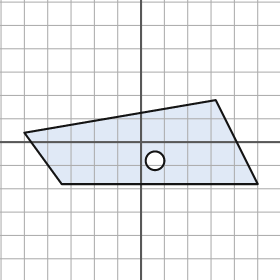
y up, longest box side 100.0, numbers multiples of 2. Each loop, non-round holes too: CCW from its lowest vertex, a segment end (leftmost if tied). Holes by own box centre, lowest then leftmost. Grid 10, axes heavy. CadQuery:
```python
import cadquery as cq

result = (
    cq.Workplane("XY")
    .moveTo(-34.0, -18.0)
    .lineTo(50.0, -18.0)
    .lineTo(32.0, 18.0)
    .lineTo(-50.0, 4.0)
    .close()
    .moveTo(6.0, -8.0)
    .circle(4.0)
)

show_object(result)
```